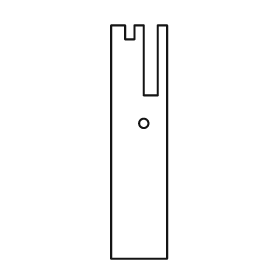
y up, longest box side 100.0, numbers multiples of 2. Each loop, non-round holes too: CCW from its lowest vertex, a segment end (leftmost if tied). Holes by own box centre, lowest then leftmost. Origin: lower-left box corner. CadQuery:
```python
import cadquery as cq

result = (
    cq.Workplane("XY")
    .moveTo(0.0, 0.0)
    .lineTo(24.0, 0.0)
    .lineTo(24.0, 100.0)
    .lineTo(20.0, 100.0)
    .lineTo(20.0, 70.0)
    .lineTo(14.0, 70.0)
    .lineTo(14.0, 100.0)
    .lineTo(10.0, 100.0)
    .lineTo(10.0, 94.0)
    .lineTo(6.0, 94.0)
    .lineTo(6.0, 100.0)
    .lineTo(0.0, 100.0)
    .close()
    .moveTo(14.0, 58.0)
    .circle(2.0)
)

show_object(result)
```